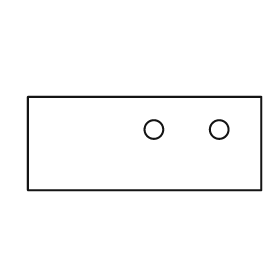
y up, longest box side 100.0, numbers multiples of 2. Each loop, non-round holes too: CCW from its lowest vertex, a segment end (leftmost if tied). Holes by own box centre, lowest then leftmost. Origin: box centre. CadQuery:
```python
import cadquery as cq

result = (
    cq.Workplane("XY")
    .moveTo(-50.0, -20.0)
    .lineTo(50.0, -20.0)
    .lineTo(50.0, 20.0)
    .lineTo(-50.0, 20.0)
    .close()
    .moveTo(4.0, 6.0)
    .circle(4.0)
    .moveTo(32.0, 6.0)
    .circle(4.0)
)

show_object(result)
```